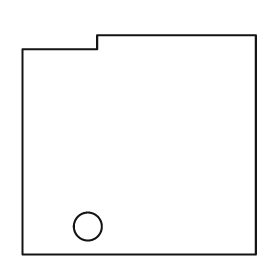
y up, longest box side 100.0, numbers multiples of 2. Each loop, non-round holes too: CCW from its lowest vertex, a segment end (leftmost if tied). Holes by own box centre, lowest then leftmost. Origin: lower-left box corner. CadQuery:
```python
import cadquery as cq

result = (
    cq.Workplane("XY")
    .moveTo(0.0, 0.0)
    .lineTo(100.0, 0.0)
    .lineTo(100.0, 94.0)
    .lineTo(32.0, 94.0)
    .lineTo(32.0, 88.0)
    .lineTo(0.0, 88.0)
    .close()
    .moveTo(28.0, 12.0)
    .circle(6.0)
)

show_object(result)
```